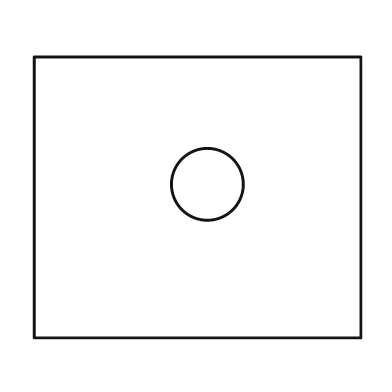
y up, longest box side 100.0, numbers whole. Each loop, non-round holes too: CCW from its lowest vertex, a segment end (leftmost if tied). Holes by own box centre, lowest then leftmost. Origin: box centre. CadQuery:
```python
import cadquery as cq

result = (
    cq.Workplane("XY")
    .moveTo(-50.0, -43.0)
    .lineTo(50.0, -43.0)
    .lineTo(50.0, 43.0)
    .lineTo(-50.0, 43.0)
    .close()
    .moveTo(3.0, 4.0)
    .circle(11.0)
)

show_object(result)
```